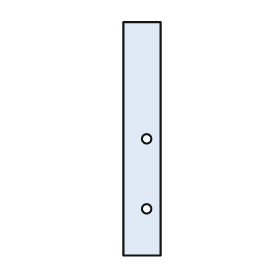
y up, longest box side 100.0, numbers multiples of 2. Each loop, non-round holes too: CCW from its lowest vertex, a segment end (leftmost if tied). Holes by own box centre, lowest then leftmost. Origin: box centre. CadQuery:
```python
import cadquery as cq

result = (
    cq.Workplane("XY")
    .moveTo(-8.0, -50.0)
    .lineTo(8.0, -50.0)
    .lineTo(8.0, 50.0)
    .lineTo(-8.0, 50.0)
    .close()
    .moveTo(2.0, -30.0)
    .circle(2.0)
    .moveTo(2.0, 0.0)
    .circle(2.0)
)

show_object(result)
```